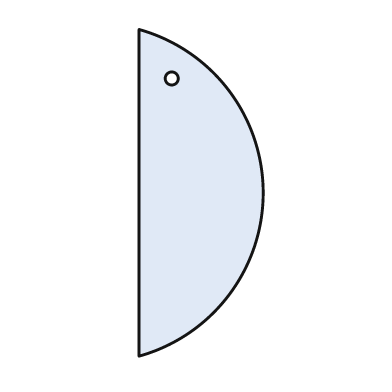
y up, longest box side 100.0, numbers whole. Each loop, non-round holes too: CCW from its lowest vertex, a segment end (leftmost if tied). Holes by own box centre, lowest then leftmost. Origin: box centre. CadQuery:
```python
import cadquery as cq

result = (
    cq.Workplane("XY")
    .moveTo(-19.0, -50.0)
    .threePointArc((19.0, 0.0), (-19.0, 50.0))
    .close()
    .moveTo(-9.0, 35.0)
    .circle(2.0)
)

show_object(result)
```